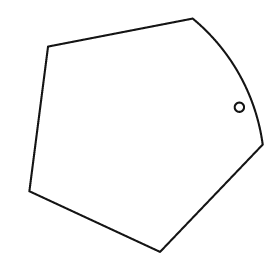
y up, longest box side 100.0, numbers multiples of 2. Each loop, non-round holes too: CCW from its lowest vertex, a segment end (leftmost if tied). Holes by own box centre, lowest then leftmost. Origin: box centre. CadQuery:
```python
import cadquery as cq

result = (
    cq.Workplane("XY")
    .moveTo(6.0, -50.0)
    .lineTo(50.0, -4.0)
    .threePointArc((40.0, 26.0), (20.0, 50.0))
    .lineTo(-42.0, 38.0)
    .lineTo(-50.0, -24.0)
    .close()
    .moveTo(40.0, 12.0)
    .circle(2.0)
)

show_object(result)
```